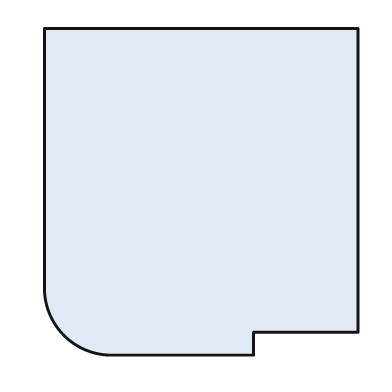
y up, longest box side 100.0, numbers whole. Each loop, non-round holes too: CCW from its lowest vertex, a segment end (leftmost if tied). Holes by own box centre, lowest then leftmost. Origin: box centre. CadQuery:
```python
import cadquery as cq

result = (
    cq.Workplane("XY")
    .moveTo(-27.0, -50.0)
    .lineTo(16.0, -50.0)
    .lineTo(16.0, -43.0)
    .lineTo(48.0, -43.0)
    .lineTo(48.0, 50.0)
    .lineTo(-48.0, 50.0)
    .lineTo(-48.0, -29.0)
    .threePointArc((-42.0, -44.0), (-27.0, -50.0))
    .close()
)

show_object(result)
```